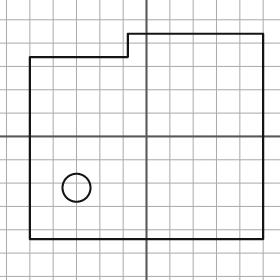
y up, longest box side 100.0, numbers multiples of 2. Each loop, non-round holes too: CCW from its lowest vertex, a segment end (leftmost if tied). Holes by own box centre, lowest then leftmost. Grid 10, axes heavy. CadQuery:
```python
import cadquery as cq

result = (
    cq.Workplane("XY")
    .moveTo(-50.0, -44.0)
    .lineTo(50.0, -44.0)
    .lineTo(50.0, 44.0)
    .lineTo(-8.0, 44.0)
    .lineTo(-8.0, 34.0)
    .lineTo(-50.0, 34.0)
    .close()
    .moveTo(-30.0, -22.0)
    .circle(6.0)
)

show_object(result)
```